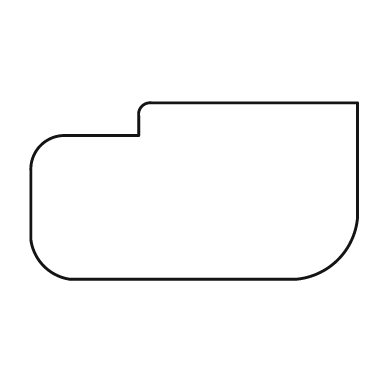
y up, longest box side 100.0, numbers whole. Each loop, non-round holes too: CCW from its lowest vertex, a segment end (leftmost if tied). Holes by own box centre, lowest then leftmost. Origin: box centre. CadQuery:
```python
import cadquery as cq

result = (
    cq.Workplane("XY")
    .moveTo(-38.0, -27.0)
    .lineTo(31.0, -27.0)
    .threePointArc((44.0, -21.0), (50.0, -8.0))
    .lineTo(50.0, 27.0)
    .lineTo(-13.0, 27.0)
    .threePointArc((-16.0, 26.0), (-17.0, 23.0))
    .lineTo(-17.0, 17.0)
    .lineTo(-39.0, 17.0)
    .threePointArc((-47.0, 14.0), (-50.0, 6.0))
    .lineTo(-50.0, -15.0)
    .threePointArc((-46.0, -23.0), (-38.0, -27.0))
    .close()
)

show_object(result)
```